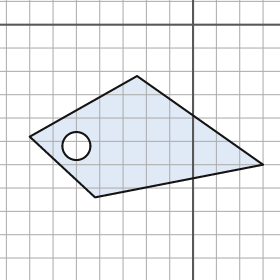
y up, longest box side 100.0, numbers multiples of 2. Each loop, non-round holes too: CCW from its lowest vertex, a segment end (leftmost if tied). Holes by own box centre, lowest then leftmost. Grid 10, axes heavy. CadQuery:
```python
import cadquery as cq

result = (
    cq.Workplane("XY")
    .moveTo(-42.0, -74.0)
    .lineTo(30.0, -60.0)
    .lineTo(-24.0, -22.0)
    .lineTo(-70.0, -48.0)
    .close()
    .moveTo(-50.0, -52.0)
    .circle(6.0)
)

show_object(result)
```